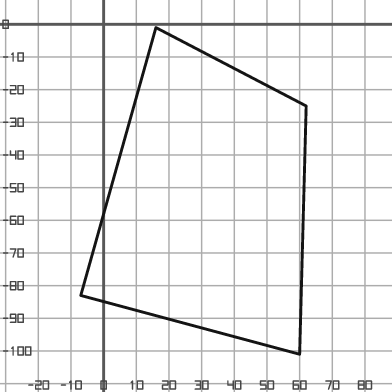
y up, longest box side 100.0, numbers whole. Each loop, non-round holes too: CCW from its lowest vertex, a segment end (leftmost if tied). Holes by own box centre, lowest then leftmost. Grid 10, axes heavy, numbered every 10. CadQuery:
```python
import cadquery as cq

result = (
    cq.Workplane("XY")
    .moveTo(60.0, -101.0)
    .lineTo(62.0, -25.0)
    .lineTo(16.0, -1.0)
    .lineTo(-7.0, -83.0)
    .close()
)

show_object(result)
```